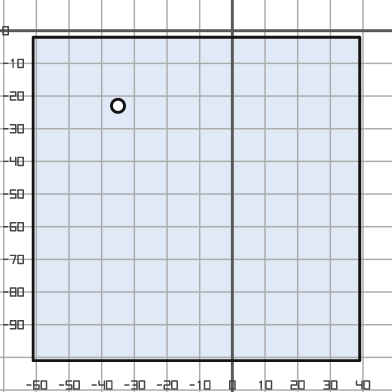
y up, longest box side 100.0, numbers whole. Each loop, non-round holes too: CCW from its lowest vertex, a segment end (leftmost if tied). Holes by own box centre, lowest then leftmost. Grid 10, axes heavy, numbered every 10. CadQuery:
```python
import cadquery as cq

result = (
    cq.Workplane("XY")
    .moveTo(-61.0, -101.0)
    .lineTo(39.0, -101.0)
    .lineTo(39.0, -2.0)
    .lineTo(-61.0, -2.0)
    .close()
    .moveTo(-35.0, -23.0)
    .circle(2.0)
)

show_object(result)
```